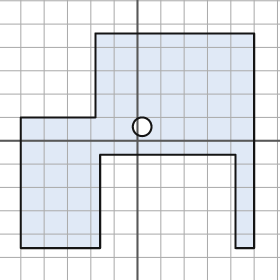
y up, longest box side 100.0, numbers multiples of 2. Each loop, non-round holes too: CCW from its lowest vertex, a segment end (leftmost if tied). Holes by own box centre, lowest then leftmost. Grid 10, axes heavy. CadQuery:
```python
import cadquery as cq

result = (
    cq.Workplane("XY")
    .moveTo(-50.0, -46.0)
    .lineTo(-16.0, -46.0)
    .lineTo(-16.0, -6.0)
    .lineTo(42.0, -6.0)
    .lineTo(42.0, -46.0)
    .lineTo(50.0, -46.0)
    .lineTo(50.0, 46.0)
    .lineTo(-18.0, 46.0)
    .lineTo(-18.0, 10.0)
    .lineTo(-50.0, 10.0)
    .close()
    .moveTo(2.0, 6.0)
    .circle(4.0)
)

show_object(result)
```